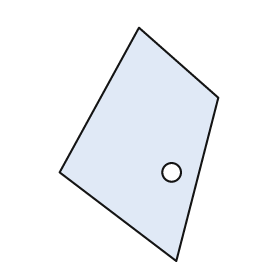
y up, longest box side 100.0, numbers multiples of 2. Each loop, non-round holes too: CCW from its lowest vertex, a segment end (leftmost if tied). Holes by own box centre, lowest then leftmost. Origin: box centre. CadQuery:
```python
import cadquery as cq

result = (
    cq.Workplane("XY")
    .moveTo(16.0, -50.0)
    .lineTo(34.0, 20.0)
    .lineTo(0.0, 50.0)
    .lineTo(-34.0, -12.0)
    .close()
    .moveTo(14.0, -12.0)
    .circle(4.0)
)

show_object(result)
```